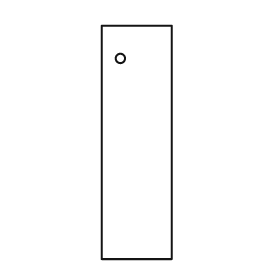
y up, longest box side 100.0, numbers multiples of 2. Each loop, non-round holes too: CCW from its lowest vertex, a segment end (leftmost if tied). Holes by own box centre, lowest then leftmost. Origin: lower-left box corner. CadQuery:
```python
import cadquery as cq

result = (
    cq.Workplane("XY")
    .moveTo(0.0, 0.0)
    .lineTo(30.0, 0.0)
    .lineTo(30.0, 100.0)
    .lineTo(0.0, 100.0)
    .close()
    .moveTo(8.0, 86.0)
    .circle(2.0)
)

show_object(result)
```